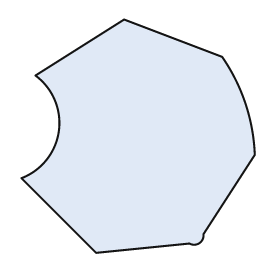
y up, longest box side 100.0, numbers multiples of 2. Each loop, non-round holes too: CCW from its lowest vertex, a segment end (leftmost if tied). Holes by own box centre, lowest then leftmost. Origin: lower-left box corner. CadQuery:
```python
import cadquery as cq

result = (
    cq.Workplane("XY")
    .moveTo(32.0, 0.0)
    .lineTo(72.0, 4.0)
    .threePointArc((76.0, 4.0), (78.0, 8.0))
    .lineTo(100.0, 42.0)
    .threePointArc((96.0, 64.0), (86.0, 84.0))
    .lineTo(44.0, 100.0)
    .lineTo(6.0, 76.0)
    .threePointArc((16.0, 52.0), (0.0, 32.0))
    .close()
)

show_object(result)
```